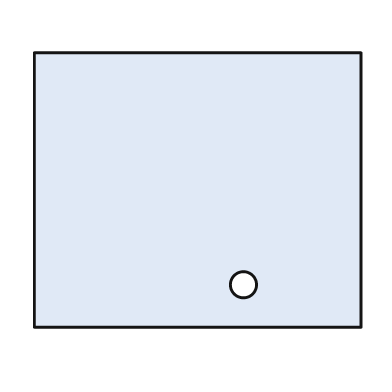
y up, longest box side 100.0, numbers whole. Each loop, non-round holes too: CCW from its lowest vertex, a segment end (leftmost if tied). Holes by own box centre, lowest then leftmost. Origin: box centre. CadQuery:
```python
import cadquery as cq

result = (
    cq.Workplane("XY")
    .moveTo(-50.0, -42.0)
    .lineTo(50.0, -42.0)
    .lineTo(50.0, 42.0)
    .lineTo(-50.0, 42.0)
    .close()
    .moveTo(14.0, -29.0)
    .circle(4.0)
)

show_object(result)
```